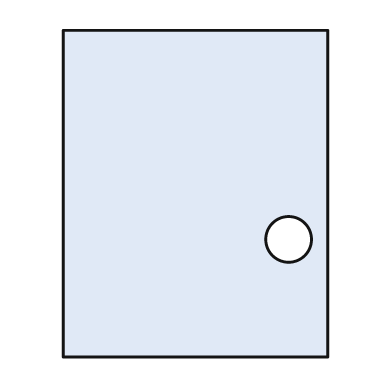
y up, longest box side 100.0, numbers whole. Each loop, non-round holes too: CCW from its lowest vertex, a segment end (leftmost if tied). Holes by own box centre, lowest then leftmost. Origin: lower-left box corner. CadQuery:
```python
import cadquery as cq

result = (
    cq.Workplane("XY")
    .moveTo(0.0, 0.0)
    .lineTo(81.0, 0.0)
    .lineTo(81.0, 100.0)
    .lineTo(0.0, 100.0)
    .close()
    .moveTo(69.0, 36.0)
    .circle(7.0)
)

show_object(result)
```